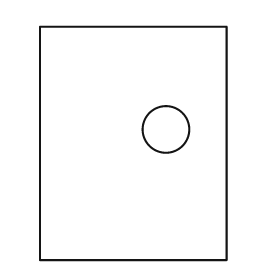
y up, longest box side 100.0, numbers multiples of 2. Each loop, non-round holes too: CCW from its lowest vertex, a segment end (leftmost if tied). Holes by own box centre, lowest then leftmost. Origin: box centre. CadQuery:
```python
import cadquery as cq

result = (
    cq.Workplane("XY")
    .moveTo(-40.0, -50.0)
    .lineTo(40.0, -50.0)
    .lineTo(40.0, 50.0)
    .lineTo(-40.0, 50.0)
    .close()
    .moveTo(14.0, 6.0)
    .circle(10.0)
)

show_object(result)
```